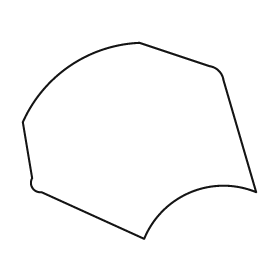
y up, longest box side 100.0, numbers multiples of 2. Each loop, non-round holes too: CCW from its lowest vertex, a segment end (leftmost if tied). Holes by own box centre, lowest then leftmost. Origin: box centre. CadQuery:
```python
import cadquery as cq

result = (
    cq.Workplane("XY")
    .moveTo(2.0, -42.0)
    .threePointArc((22.0, -22.0), (50.0, -22.0))
    .lineTo(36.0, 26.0)
    .threePointArc((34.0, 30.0), (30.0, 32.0))
    .lineTo(0.0, 42.0)
    .threePointArc((-30.0, 32.0), (-50.0, 8.0))
    .lineTo(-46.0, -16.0)
    .threePointArc((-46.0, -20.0), (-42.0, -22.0))
    .close()
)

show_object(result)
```